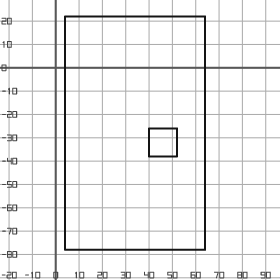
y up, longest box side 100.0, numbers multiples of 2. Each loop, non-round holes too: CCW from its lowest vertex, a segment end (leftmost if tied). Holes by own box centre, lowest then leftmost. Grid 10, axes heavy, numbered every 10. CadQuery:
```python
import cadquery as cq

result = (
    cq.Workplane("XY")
    .moveTo(4.0, -78.0)
    .lineTo(64.0, -78.0)
    .lineTo(64.0, 22.0)
    .lineTo(4.0, 22.0)
    .close()
    .moveTo(40.0, -38.0)
    .lineTo(52.0, -38.0)
    .lineTo(52.0, -26.0)
    .lineTo(40.0, -26.0)
    .close()
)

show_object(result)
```